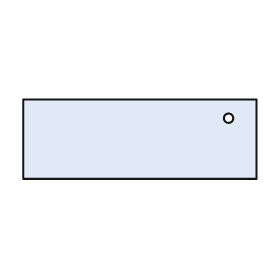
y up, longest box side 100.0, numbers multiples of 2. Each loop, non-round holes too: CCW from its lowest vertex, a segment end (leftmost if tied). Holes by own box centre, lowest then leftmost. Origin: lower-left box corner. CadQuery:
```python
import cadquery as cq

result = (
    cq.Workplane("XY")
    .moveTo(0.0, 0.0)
    .lineTo(100.0, 0.0)
    .lineTo(100.0, 34.0)
    .lineTo(0.0, 34.0)
    .close()
    .moveTo(88.0, 26.0)
    .circle(2.0)
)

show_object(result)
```